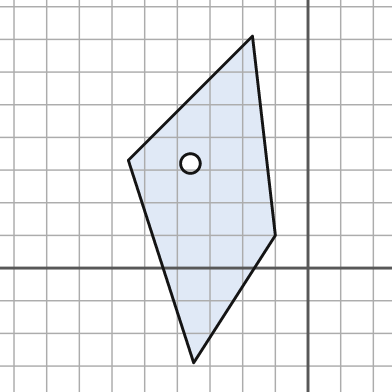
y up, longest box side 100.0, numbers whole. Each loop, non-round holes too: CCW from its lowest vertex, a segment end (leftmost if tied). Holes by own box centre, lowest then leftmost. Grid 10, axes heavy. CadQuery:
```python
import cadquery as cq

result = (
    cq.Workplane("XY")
    .moveTo(-35.0, -29.0)
    .lineTo(-10.0, 10.0)
    .lineTo(-17.0, 71.0)
    .lineTo(-55.0, 33.0)
    .close()
    .moveTo(-36.0, 32.0)
    .circle(3.0)
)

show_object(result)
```